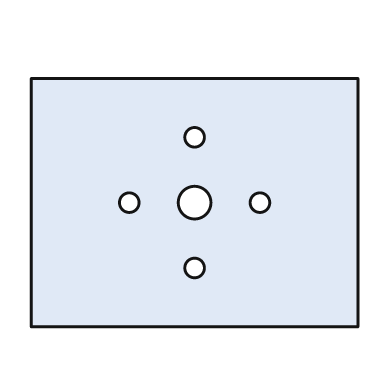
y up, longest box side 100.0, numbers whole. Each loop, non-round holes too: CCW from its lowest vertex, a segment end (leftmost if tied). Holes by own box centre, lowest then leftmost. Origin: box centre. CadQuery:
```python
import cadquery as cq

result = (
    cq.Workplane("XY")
    .moveTo(-50.0, -38.0)
    .lineTo(50.0, -38.0)
    .lineTo(50.0, 38.0)
    .lineTo(-50.0, 38.0)
    .close()
    .moveTo(0.0, -20.0)
    .circle(3.0)
    .moveTo(-20.0, 0.0)
    .circle(3.0)
    .moveTo(0.0, 0.0)
    .circle(5.0)
    .moveTo(20.0, 0.0)
    .circle(3.0)
    .moveTo(0.0, 20.0)
    .circle(3.0)
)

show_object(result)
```